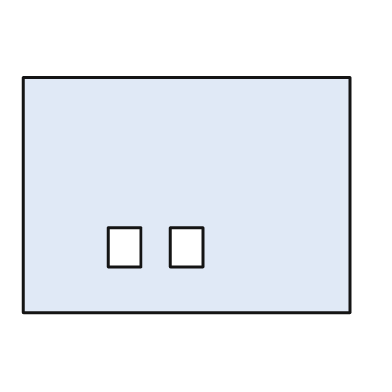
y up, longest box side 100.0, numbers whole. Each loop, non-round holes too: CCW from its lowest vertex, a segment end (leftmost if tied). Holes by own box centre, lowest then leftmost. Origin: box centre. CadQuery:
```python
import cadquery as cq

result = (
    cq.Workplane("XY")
    .moveTo(-50.0, -36.0)
    .lineTo(50.0, -36.0)
    .lineTo(50.0, 36.0)
    .lineTo(-50.0, 36.0)
    .close()
    .moveTo(-24.0, -22.0)
    .lineTo(-14.0, -22.0)
    .lineTo(-14.0, -10.0)
    .lineTo(-24.0, -10.0)
    .close()
    .moveTo(-5.0, -22.0)
    .lineTo(5.0, -22.0)
    .lineTo(5.0, -10.0)
    .lineTo(-5.0, -10.0)
    .close()
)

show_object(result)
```